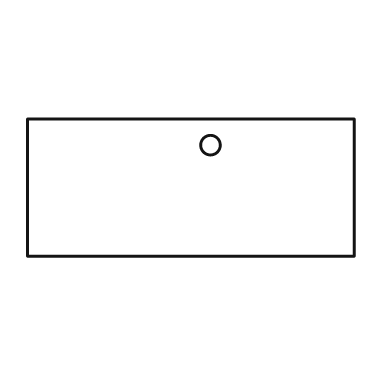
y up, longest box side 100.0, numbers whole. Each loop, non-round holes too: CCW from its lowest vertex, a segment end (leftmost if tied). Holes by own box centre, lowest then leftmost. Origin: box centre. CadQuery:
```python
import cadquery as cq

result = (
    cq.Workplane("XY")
    .moveTo(-50.0, -21.0)
    .lineTo(50.0, -21.0)
    .lineTo(50.0, 21.0)
    .lineTo(-50.0, 21.0)
    .close()
    .moveTo(6.0, 13.0)
    .circle(3.0)
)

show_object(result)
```